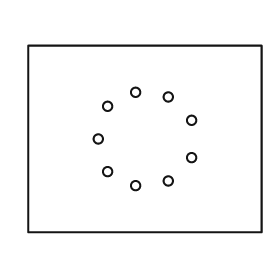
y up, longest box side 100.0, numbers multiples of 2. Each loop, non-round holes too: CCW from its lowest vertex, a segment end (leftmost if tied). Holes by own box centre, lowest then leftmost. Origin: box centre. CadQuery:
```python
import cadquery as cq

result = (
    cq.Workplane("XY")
    .moveTo(-50.0, -40.0)
    .lineTo(50.0, -40.0)
    .lineTo(50.0, 40.0)
    .lineTo(-50.0, 40.0)
    .close()
    .moveTo(-4.0, -20.0)
    .circle(2.0)
    .moveTo(10.0, -18.0)
    .circle(2.0)
    .moveTo(-16.0, -14.0)
    .circle(2.0)
    .moveTo(20.0, -8.0)
    .circle(2.0)
    .moveTo(-20.0, 0.0)
    .circle(2.0)
    .moveTo(20.0, 8.0)
    .circle(2.0)
    .moveTo(-16.0, 14.0)
    .circle(2.0)
    .moveTo(10.0, 18.0)
    .circle(2.0)
    .moveTo(-4.0, 20.0)
    .circle(2.0)
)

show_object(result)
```